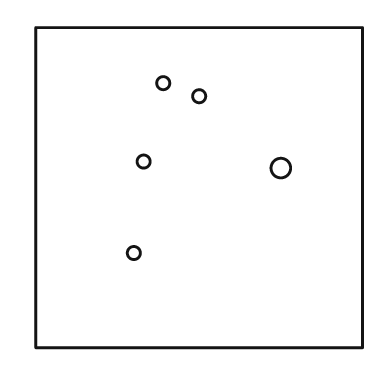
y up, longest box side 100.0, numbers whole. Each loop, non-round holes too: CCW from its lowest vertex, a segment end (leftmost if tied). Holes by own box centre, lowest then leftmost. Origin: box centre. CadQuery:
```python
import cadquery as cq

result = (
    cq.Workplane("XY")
    .moveTo(-50.0, -49.0)
    .lineTo(50.0, -49.0)
    .lineTo(50.0, 49.0)
    .lineTo(-50.0, 49.0)
    .close()
    .moveTo(-20.0, -20.0)
    .circle(2.0)
    .moveTo(25.0, 6.0)
    .circle(3.0)
    .moveTo(-17.0, 8.0)
    .circle(2.0)
    .moveTo(0.0, 28.0)
    .circle(2.0)
    .moveTo(-11.0, 32.0)
    .circle(2.0)
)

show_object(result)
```